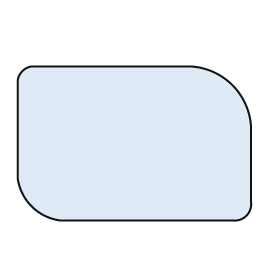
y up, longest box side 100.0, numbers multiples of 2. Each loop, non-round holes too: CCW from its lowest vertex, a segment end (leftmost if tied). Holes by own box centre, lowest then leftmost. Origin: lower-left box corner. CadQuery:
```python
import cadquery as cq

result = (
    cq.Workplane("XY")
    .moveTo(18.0, 0.0)
    .lineTo(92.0, 0.0)
    .threePointArc((98.0, 2.0), (100.0, 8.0))
    .lineTo(100.0, 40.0)
    .threePointArc((92.0, 58.0), (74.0, 66.0))
    .lineTo(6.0, 66.0)
    .threePointArc((2.0, 64.0), (0.0, 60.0))
    .lineTo(0.0, 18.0)
    .threePointArc((6.0, 6.0), (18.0, 0.0))
    .close()
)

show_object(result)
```